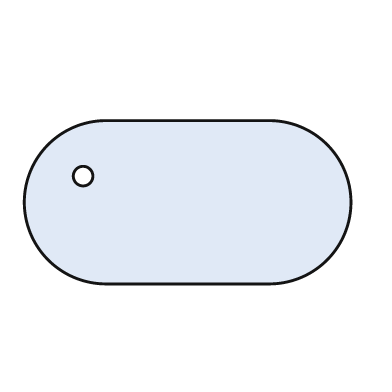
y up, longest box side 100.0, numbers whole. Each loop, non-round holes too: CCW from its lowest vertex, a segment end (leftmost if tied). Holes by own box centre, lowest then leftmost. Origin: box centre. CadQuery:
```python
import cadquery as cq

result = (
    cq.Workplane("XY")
    .moveTo(-25.0, -25.0)
    .lineTo(25.0, -25.0)
    .threePointArc((50.0, 0.0), (25.0, 25.0))
    .lineTo(-25.0, 25.0)
    .threePointArc((-50.0, 0.0), (-25.0, -25.0))
    .close()
    .moveTo(-32.0, 8.0)
    .circle(3.0)
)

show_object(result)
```